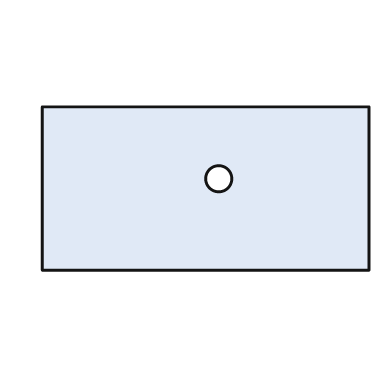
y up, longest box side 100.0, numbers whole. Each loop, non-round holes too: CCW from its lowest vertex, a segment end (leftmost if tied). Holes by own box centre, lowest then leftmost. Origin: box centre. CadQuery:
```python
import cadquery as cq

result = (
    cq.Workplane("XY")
    .moveTo(-50.0, -25.0)
    .lineTo(50.0, -25.0)
    .lineTo(50.0, 25.0)
    .lineTo(-50.0, 25.0)
    .close()
    .moveTo(4.0, 3.0)
    .circle(4.0)
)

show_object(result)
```